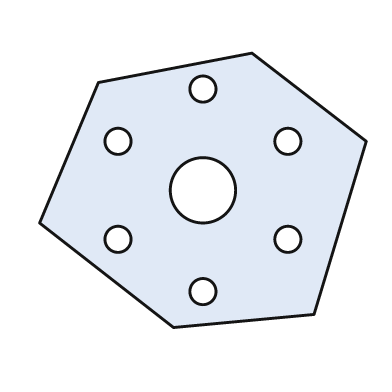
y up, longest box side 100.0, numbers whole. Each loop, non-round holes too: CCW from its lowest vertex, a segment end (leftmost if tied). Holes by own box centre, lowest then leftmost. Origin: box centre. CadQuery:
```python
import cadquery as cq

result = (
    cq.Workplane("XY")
    .moveTo(-9.0, -42.0)
    .lineTo(34.0, -38.0)
    .lineTo(50.0, 15.0)
    .lineTo(15.0, 42.0)
    .lineTo(-32.0, 33.0)
    .lineTo(-50.0, -10.0)
    .close()
    .moveTo(0.0, -31.0)
    .circle(4.0)
    .moveTo(-26.0, -15.0)
    .circle(4.0)
    .moveTo(26.0, -15.0)
    .circle(4.0)
    .moveTo(0.0, 0.0)
    .circle(10.0)
    .moveTo(-26.0, 15.0)
    .circle(4.0)
    .moveTo(26.0, 15.0)
    .circle(4.0)
    .moveTo(0.0, 31.0)
    .circle(4.0)
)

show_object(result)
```